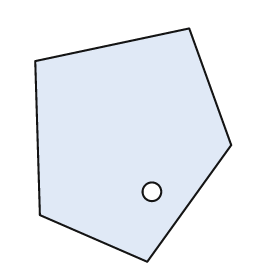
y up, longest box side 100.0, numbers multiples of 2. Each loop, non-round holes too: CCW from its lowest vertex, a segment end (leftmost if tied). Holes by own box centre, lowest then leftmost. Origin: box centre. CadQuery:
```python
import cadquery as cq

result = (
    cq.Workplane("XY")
    .moveTo(6.0, -50.0)
    .lineTo(42.0, 0.0)
    .lineTo(24.0, 50.0)
    .lineTo(-42.0, 36.0)
    .lineTo(-40.0, -30.0)
    .close()
    .moveTo(8.0, -20.0)
    .circle(4.0)
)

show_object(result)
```